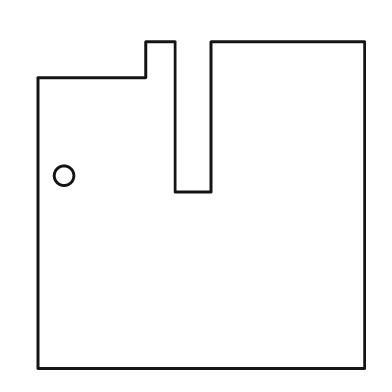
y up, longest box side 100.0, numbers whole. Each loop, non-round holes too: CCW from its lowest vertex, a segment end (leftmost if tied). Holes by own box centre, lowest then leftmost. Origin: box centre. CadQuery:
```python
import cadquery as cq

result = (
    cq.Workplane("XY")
    .moveTo(-50.0, -50.0)
    .lineTo(50.0, -50.0)
    .lineTo(50.0, 50.0)
    .lineTo(3.0, 50.0)
    .lineTo(3.0, 4.0)
    .lineTo(-8.0, 4.0)
    .lineTo(-8.0, 50.0)
    .lineTo(-17.0, 50.0)
    .lineTo(-17.0, 39.0)
    .lineTo(-50.0, 39.0)
    .close()
    .moveTo(-42.0, 9.0)
    .circle(3.0)
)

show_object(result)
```